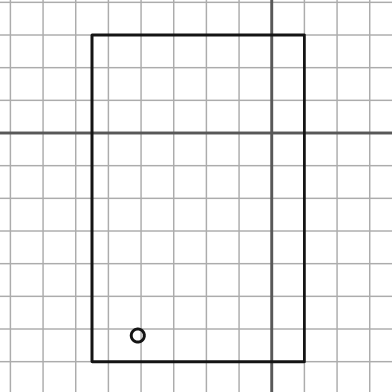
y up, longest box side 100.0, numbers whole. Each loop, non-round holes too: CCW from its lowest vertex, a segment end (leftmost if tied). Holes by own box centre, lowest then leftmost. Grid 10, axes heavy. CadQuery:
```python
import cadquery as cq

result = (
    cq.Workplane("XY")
    .moveTo(-55.0, -70.0)
    .lineTo(10.0, -70.0)
    .lineTo(10.0, 30.0)
    .lineTo(-55.0, 30.0)
    .close()
    .moveTo(-41.0, -62.0)
    .circle(2.0)
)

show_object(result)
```